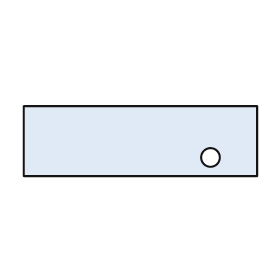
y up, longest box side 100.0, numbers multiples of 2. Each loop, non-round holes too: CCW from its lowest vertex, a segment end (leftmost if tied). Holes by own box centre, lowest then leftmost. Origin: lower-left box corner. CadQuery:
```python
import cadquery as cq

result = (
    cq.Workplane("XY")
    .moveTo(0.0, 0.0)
    .lineTo(100.0, 0.0)
    .lineTo(100.0, 30.0)
    .lineTo(0.0, 30.0)
    .close()
    .moveTo(80.0, 8.0)
    .circle(4.0)
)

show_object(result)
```